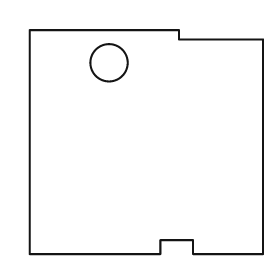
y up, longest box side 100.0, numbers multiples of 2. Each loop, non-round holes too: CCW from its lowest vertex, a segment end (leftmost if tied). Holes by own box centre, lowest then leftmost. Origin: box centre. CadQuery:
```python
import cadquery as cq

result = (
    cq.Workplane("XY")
    .moveTo(-50.0, -48.0)
    .lineTo(6.0, -48.0)
    .lineTo(6.0, -42.0)
    .lineTo(20.0, -42.0)
    .lineTo(20.0, -48.0)
    .lineTo(50.0, -48.0)
    .lineTo(50.0, 44.0)
    .lineTo(14.0, 44.0)
    .lineTo(14.0, 48.0)
    .lineTo(-50.0, 48.0)
    .close()
    .moveTo(-16.0, 34.0)
    .circle(8.0)
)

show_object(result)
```